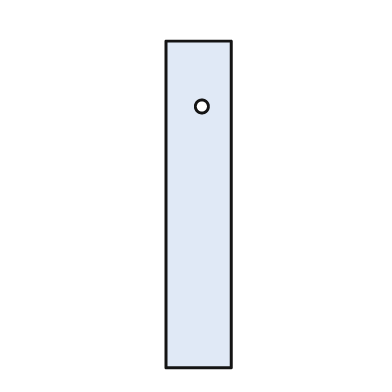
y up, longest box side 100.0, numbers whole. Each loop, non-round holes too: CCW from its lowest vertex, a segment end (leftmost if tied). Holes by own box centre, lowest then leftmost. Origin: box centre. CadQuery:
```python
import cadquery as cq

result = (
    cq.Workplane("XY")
    .moveTo(-10.0, -50.0)
    .lineTo(10.0, -50.0)
    .lineTo(10.0, 50.0)
    .lineTo(-10.0, 50.0)
    .close()
    .moveTo(1.0, 30.0)
    .circle(2.0)
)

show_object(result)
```